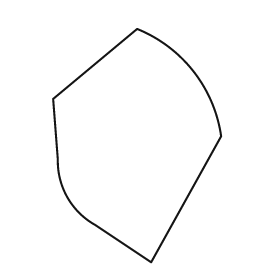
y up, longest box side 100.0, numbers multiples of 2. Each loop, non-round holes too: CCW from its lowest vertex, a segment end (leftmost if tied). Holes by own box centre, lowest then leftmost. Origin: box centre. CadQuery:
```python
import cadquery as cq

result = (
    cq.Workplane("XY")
    .moveTo(6.0, -50.0)
    .lineTo(36.0, 4.0)
    .threePointArc((24.0, 32.0), (0.0, 50.0))
    .lineTo(-36.0, 20.0)
    .lineTo(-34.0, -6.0)
    .threePointArc((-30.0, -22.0), (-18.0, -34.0))
    .close()
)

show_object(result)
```